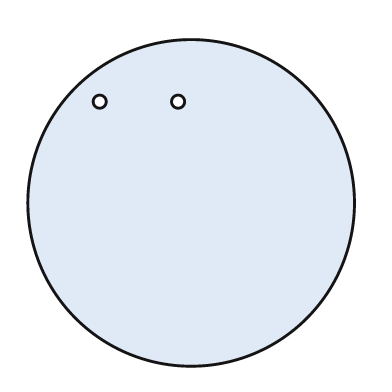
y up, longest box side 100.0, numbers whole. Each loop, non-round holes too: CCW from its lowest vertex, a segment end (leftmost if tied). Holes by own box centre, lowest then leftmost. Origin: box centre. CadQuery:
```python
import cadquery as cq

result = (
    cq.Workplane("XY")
    .moveTo(0.0, 0.0)
    .circle(50.0)
    .moveTo(-28.0, 31.0)
    .circle(2.0)
    .moveTo(-4.0, 31.0)
    .circle(2.0)
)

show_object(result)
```